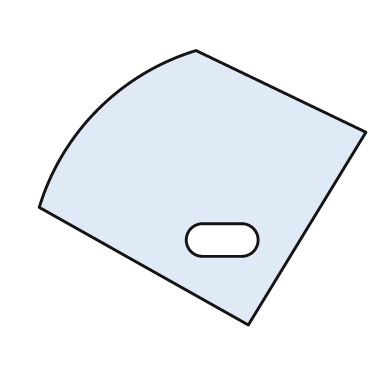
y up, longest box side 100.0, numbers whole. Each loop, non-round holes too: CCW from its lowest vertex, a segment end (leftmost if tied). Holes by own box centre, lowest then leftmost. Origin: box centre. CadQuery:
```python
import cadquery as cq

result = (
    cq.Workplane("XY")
    .moveTo(14.0, -42.0)
    .lineTo(50.0, 17.0)
    .lineTo(-2.0, 42.0)
    .threePointArc((-32.0, 24.0), (-50.0, -6.0))
    .close()
    .moveTo(0.0, -21.0)
    .lineTo(12.0, -21.0)
    .threePointArc((17.0, -16.0), (12.0, -11.0))
    .lineTo(0.0, -11.0)
    .threePointArc((-5.0, -16.0), (0.0, -21.0))
    .close()
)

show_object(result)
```